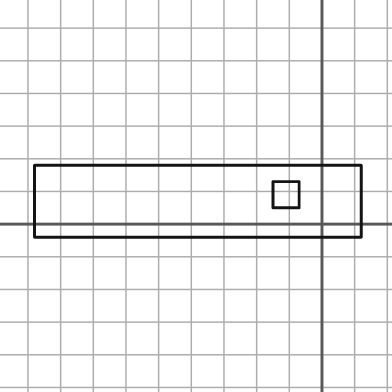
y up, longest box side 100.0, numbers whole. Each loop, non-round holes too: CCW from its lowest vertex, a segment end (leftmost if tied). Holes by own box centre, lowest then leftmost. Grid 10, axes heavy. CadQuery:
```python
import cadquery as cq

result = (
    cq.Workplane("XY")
    .moveTo(-88.0, -4.0)
    .lineTo(12.0, -4.0)
    .lineTo(12.0, 18.0)
    .lineTo(-88.0, 18.0)
    .close()
    .moveTo(-15.0, 5.0)
    .lineTo(-7.0, 5.0)
    .lineTo(-7.0, 13.0)
    .lineTo(-15.0, 13.0)
    .close()
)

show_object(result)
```